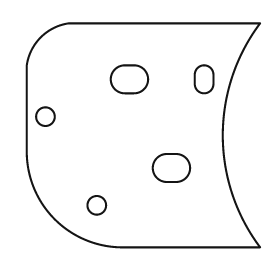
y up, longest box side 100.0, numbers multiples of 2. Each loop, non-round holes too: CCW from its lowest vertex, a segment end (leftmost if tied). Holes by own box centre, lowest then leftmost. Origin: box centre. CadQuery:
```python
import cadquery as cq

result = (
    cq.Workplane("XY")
    .moveTo(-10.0, -48.0)
    .lineTo(50.0, -48.0)
    .threePointArc((34.0, 0.0), (50.0, 48.0))
    .lineTo(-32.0, 48.0)
    .threePointArc((-44.0, 42.0), (-50.0, 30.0))
    .lineTo(-50.0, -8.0)
    .threePointArc((-38.0, -36.0), (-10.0, -48.0))
    .close()
    .moveTo(-20.0, -30.0)
    .circle(4.0)
    .moveTo(10.0, -20.0)
    .lineTo(14.0, -20.0)
    .threePointArc((20.0, -14.0), (14.0, -8.0))
    .lineTo(10.0, -8.0)
    .threePointArc((4.0, -14.0), (10.0, -20.0))
    .close()
    .moveTo(-42.0, 8.0)
    .circle(4.0)
    .moveTo(-8.0, 18.0)
    .lineTo(-4.0, 18.0)
    .threePointArc((2.0, 24.0), (-4.0, 30.0))
    .lineTo(-8.0, 30.0)
    .threePointArc((-14.0, 24.0), (-8.0, 18.0))
    .close()
    .moveTo(22.0, 22.0)
    .threePointArc((26.0, 18.0), (30.0, 22.0))
    .lineTo(30.0, 26.0)
    .threePointArc((26.0, 30.0), (22.0, 26.0))
    .close()
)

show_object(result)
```